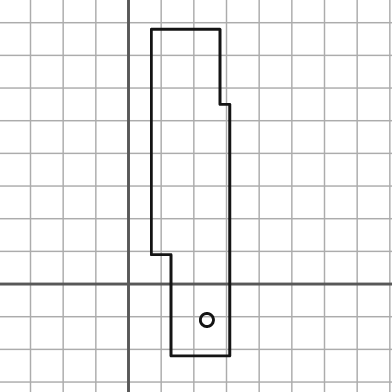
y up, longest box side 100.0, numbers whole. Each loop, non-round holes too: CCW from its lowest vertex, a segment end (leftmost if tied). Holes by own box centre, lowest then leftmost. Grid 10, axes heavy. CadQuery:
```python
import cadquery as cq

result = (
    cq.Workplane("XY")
    .moveTo(13.0, -22.0)
    .lineTo(31.0, -22.0)
    .lineTo(31.0, 55.0)
    .lineTo(28.0, 55.0)
    .lineTo(28.0, 78.0)
    .lineTo(7.0, 78.0)
    .lineTo(7.0, 9.0)
    .lineTo(13.0, 9.0)
    .close()
    .moveTo(24.0, -11.0)
    .circle(2.0)
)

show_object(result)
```